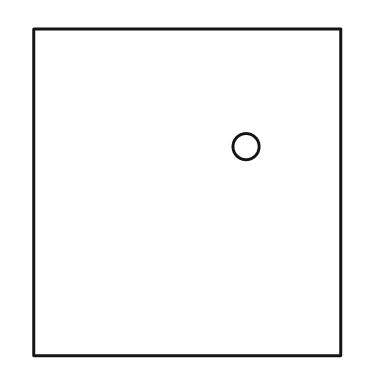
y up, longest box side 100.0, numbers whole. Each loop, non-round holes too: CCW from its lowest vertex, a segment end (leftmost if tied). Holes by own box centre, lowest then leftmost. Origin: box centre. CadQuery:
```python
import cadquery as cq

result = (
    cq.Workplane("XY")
    .moveTo(-47.0, -50.0)
    .lineTo(47.0, -50.0)
    .lineTo(47.0, 50.0)
    .lineTo(-47.0, 50.0)
    .close()
    .moveTo(18.0, 14.0)
    .circle(4.0)
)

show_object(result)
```